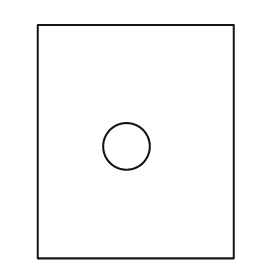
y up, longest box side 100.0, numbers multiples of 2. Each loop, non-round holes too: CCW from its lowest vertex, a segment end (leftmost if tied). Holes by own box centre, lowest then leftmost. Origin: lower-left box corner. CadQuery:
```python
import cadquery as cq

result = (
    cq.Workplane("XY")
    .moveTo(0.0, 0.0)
    .lineTo(84.0, 0.0)
    .lineTo(84.0, 100.0)
    .lineTo(0.0, 100.0)
    .close()
    .moveTo(38.0, 48.0)
    .circle(10.0)
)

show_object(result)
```